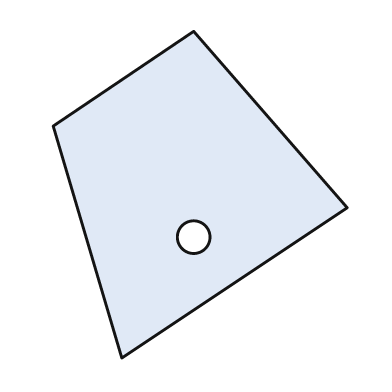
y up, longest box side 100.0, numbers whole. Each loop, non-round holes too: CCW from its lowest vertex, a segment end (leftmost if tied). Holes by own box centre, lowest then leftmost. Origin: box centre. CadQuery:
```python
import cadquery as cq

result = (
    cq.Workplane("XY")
    .moveTo(-24.0, -50.0)
    .lineTo(45.0, -4.0)
    .lineTo(-2.0, 50.0)
    .lineTo(-45.0, 21.0)
    .close()
    .moveTo(-2.0, -13.0)
    .circle(5.0)
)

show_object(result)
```